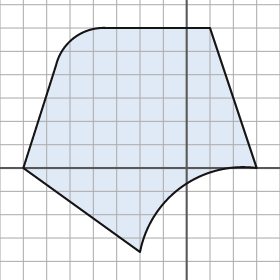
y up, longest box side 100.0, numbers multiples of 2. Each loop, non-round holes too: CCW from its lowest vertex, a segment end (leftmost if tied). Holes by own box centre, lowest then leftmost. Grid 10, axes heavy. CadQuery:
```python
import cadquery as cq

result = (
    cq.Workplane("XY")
    .moveTo(-20.0, -36.0)
    .threePointArc((-2.0, -8.0), (30.0, 0.0))
    .lineTo(10.0, 60.0)
    .lineTo(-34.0, 60.0)
    .threePointArc((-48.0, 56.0), (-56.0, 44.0))
    .lineTo(-70.0, 0.0)
    .close()
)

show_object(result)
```